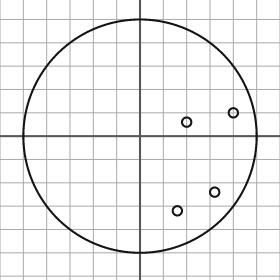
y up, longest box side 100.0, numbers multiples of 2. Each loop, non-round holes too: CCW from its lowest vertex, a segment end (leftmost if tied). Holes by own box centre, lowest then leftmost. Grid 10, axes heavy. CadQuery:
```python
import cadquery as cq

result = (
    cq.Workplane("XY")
    .moveTo(0.0, 0.0)
    .circle(50.0)
    .moveTo(16.0, -32.0)
    .circle(2.0)
    .moveTo(32.0, -24.0)
    .circle(2.0)
    .moveTo(20.0, 6.0)
    .circle(2.0)
    .moveTo(40.0, 10.0)
    .circle(2.0)
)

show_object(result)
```